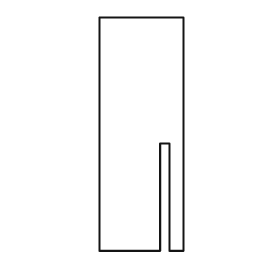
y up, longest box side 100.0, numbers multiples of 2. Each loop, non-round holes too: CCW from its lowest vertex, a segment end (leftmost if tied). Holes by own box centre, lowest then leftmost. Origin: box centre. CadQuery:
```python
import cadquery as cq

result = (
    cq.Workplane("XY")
    .moveTo(-18.0, -50.0)
    .lineTo(8.0, -50.0)
    .lineTo(8.0, -4.0)
    .lineTo(12.0, -4.0)
    .lineTo(12.0, -50.0)
    .lineTo(18.0, -50.0)
    .lineTo(18.0, 50.0)
    .lineTo(-18.0, 50.0)
    .close()
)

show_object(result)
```